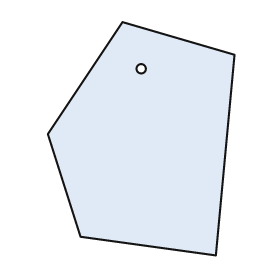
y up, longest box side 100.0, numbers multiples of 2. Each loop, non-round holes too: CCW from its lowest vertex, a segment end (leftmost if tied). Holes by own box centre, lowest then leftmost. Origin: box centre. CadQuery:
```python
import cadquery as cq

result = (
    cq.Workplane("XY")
    .moveTo(32.0, -50.0)
    .lineTo(40.0, 36.0)
    .lineTo(-8.0, 50.0)
    .lineTo(-40.0, 2.0)
    .lineTo(-26.0, -42.0)
    .close()
    .moveTo(0.0, 30.0)
    .circle(2.0)
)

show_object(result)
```